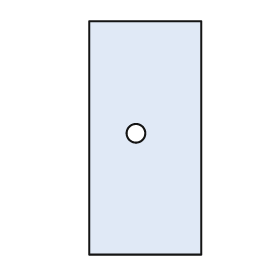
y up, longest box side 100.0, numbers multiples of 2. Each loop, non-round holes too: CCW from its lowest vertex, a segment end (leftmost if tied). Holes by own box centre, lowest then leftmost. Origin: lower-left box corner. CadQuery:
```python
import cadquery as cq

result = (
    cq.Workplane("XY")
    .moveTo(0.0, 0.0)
    .lineTo(48.0, 0.0)
    .lineTo(48.0, 100.0)
    .lineTo(0.0, 100.0)
    .close()
    .moveTo(20.0, 52.0)
    .circle(4.0)
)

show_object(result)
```